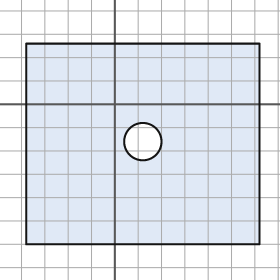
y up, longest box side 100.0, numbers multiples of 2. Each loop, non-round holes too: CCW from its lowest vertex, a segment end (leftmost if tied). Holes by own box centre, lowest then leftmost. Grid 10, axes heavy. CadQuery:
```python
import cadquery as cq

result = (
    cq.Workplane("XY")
    .moveTo(-38.0, -60.0)
    .lineTo(62.0, -60.0)
    .lineTo(62.0, 26.0)
    .lineTo(-38.0, 26.0)
    .close()
    .moveTo(12.0, -16.0)
    .circle(8.0)
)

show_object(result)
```